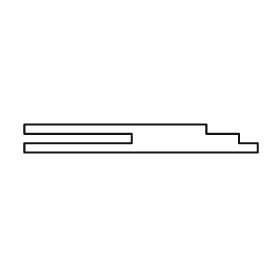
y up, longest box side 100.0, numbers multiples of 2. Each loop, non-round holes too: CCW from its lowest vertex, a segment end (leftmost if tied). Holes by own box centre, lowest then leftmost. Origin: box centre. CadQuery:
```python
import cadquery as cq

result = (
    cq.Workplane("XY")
    .moveTo(-50.0, -6.0)
    .lineTo(50.0, -6.0)
    .lineTo(50.0, -2.0)
    .lineTo(42.0, -2.0)
    .lineTo(42.0, 2.0)
    .lineTo(28.0, 2.0)
    .lineTo(28.0, 6.0)
    .lineTo(-50.0, 6.0)
    .lineTo(-50.0, 2.0)
    .lineTo(-4.0, 2.0)
    .lineTo(-4.0, -2.0)
    .lineTo(-50.0, -2.0)
    .close()
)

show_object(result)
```